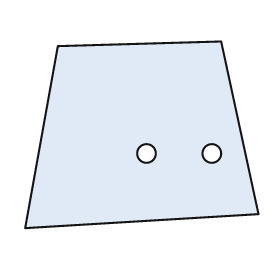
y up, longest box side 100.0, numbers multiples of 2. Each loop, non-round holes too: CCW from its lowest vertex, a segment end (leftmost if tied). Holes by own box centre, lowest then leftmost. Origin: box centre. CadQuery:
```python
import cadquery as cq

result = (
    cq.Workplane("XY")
    .moveTo(-50.0, -40.0)
    .lineTo(50.0, -34.0)
    .lineTo(34.0, 40.0)
    .lineTo(-36.0, 38.0)
    .close()
    .moveTo(2.0, -8.0)
    .circle(4.0)
    .moveTo(30.0, -8.0)
    .circle(4.0)
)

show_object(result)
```